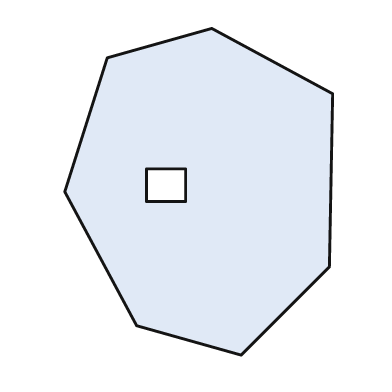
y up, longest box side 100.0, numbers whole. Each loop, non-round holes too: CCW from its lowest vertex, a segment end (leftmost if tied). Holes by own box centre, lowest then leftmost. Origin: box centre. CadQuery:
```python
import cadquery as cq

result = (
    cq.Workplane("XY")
    .moveTo(13.0, -50.0)
    .lineTo(40.0, -23.0)
    .lineTo(41.0, 30.0)
    .lineTo(4.0, 50.0)
    .lineTo(-28.0, 41.0)
    .lineTo(-41.0, 0.0)
    .lineTo(-19.0, -41.0)
    .close()
    .moveTo(-16.0, -3.0)
    .lineTo(-4.0, -3.0)
    .lineTo(-4.0, 7.0)
    .lineTo(-16.0, 7.0)
    .close()
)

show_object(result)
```